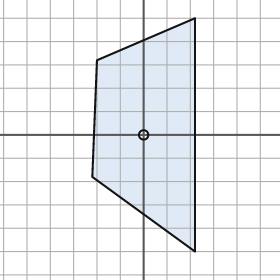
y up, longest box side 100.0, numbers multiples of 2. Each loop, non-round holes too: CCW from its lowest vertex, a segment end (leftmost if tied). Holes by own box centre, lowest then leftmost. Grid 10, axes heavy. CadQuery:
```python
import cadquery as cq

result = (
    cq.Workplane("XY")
    .moveTo(22.0, -50.0)
    .lineTo(22.0, 50.0)
    .lineTo(-20.0, 32.0)
    .lineTo(-22.0, -18.0)
    .close()
    .moveTo(0.0, 0.0)
    .circle(2.0)
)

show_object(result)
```